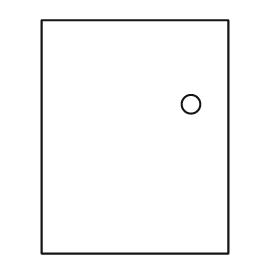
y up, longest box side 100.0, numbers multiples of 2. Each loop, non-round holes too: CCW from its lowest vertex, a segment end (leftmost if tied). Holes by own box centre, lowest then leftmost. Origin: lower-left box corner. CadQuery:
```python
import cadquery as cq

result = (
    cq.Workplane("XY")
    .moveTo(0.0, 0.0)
    .lineTo(80.0, 0.0)
    .lineTo(80.0, 100.0)
    .lineTo(0.0, 100.0)
    .close()
    .moveTo(64.0, 64.0)
    .circle(4.0)
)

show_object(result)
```